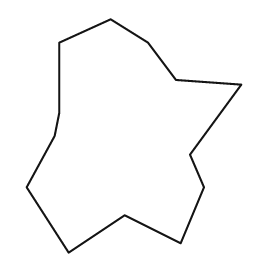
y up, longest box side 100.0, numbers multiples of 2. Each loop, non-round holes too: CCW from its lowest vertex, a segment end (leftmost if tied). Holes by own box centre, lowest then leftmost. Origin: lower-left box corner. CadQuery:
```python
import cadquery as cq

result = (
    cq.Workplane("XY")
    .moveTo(18.0, 0.0)
    .lineTo(42.0, 16.0)
    .lineTo(66.0, 4.0)
    .lineTo(76.0, 28.0)
    .lineTo(70.0, 42.0)
    .lineTo(92.0, 72.0)
    .lineTo(64.0, 74.0)
    .lineTo(52.0, 90.0)
    .lineTo(36.0, 100.0)
    .lineTo(14.0, 90.0)
    .lineTo(14.0, 60.0)
    .lineTo(12.0, 50.0)
    .lineTo(0.0, 28.0)
    .close()
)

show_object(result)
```